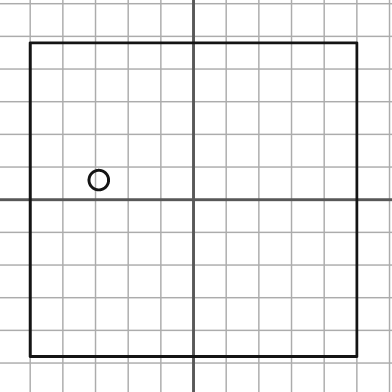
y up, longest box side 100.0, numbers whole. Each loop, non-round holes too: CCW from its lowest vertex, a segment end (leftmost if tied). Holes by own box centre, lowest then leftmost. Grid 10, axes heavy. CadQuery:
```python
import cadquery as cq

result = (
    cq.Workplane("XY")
    .moveTo(-50.0, -48.0)
    .lineTo(50.0, -48.0)
    .lineTo(50.0, 48.0)
    .lineTo(-50.0, 48.0)
    .close()
    .moveTo(-29.0, 6.0)
    .circle(3.0)
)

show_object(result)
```